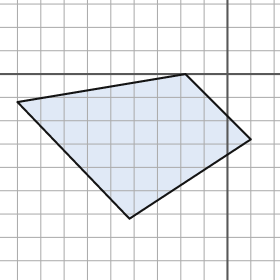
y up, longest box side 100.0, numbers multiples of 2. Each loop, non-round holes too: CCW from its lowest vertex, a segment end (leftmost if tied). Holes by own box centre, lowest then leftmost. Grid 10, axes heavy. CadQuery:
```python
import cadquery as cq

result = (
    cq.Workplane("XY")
    .moveTo(-42.0, -62.0)
    .lineTo(10.0, -28.0)
    .lineTo(-18.0, 0.0)
    .lineTo(-90.0, -12.0)
    .close()
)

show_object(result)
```